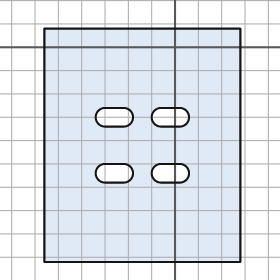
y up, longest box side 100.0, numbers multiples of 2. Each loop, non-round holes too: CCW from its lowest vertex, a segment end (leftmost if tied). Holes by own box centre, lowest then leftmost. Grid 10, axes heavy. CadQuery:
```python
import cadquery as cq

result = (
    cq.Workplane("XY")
    .moveTo(-56.0, -92.0)
    .lineTo(28.0, -92.0)
    .lineTo(28.0, 8.0)
    .lineTo(-56.0, 8.0)
    .close()
    .moveTo(-30.0, -58.0)
    .lineTo(-22.0, -58.0)
    .threePointArc((-18.0, -54.0), (-22.0, -50.0))
    .lineTo(-30.0, -50.0)
    .threePointArc((-34.0, -54.0), (-30.0, -58.0))
    .close()
    .moveTo(-6.0, -58.0)
    .lineTo(2.0, -58.0)
    .threePointArc((6.0, -54.0), (2.0, -50.0))
    .lineTo(-6.0, -50.0)
    .threePointArc((-10.0, -54.0), (-6.0, -58.0))
    .close()
    .moveTo(-30.0, -34.0)
    .lineTo(-22.0, -34.0)
    .threePointArc((-18.0, -30.0), (-22.0, -26.0))
    .lineTo(-30.0, -26.0)
    .threePointArc((-34.0, -30.0), (-30.0, -34.0))
    .close()
    .moveTo(-6.0, -34.0)
    .lineTo(2.0, -34.0)
    .threePointArc((6.0, -30.0), (2.0, -26.0))
    .lineTo(-6.0, -26.0)
    .threePointArc((-10.0, -30.0), (-6.0, -34.0))
    .close()
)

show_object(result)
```